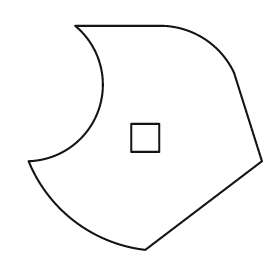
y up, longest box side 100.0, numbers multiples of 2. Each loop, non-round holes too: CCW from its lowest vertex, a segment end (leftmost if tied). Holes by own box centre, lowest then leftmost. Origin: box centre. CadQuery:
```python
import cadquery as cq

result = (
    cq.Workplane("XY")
    .moveTo(0.0, -48.0)
    .lineTo(50.0, -10.0)
    .lineTo(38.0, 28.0)
    .threePointArc((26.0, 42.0), (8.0, 48.0))
    .lineTo(-30.0, 48.0)
    .threePointArc((-20.0, 12.0), (-50.0, -10.0))
    .threePointArc((-30.0, -36.0), (0.0, -48.0))
    .close()
    .moveTo(-6.0, -6.0)
    .lineTo(6.0, -6.0)
    .lineTo(6.0, 6.0)
    .lineTo(-6.0, 6.0)
    .close()
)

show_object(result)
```